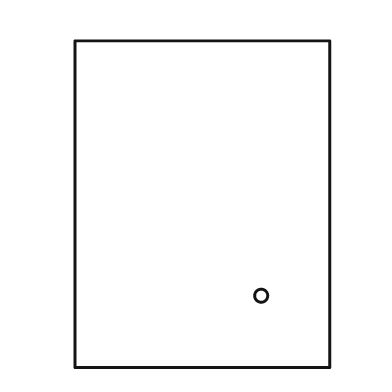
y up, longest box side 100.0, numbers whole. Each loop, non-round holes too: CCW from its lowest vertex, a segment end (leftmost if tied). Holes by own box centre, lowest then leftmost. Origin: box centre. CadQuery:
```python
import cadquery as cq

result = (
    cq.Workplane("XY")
    .moveTo(-39.0, -50.0)
    .lineTo(39.0, -50.0)
    .lineTo(39.0, 50.0)
    .lineTo(-39.0, 50.0)
    .close()
    .moveTo(18.0, -28.0)
    .circle(2.0)
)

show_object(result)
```